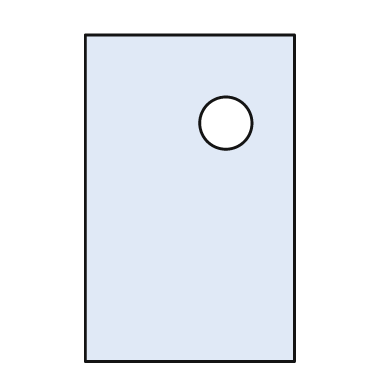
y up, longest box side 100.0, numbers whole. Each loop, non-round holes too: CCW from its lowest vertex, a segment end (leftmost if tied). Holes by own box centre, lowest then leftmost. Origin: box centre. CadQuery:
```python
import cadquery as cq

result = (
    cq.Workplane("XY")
    .moveTo(-32.0, -50.0)
    .lineTo(32.0, -50.0)
    .lineTo(32.0, 50.0)
    .lineTo(-32.0, 50.0)
    .close()
    .moveTo(11.0, 23.0)
    .circle(8.0)
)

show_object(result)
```